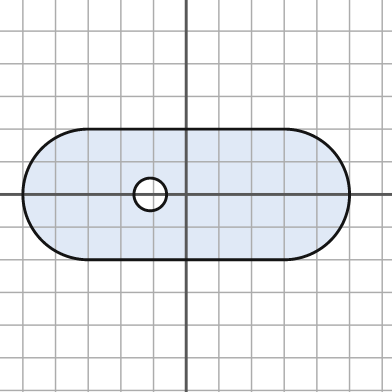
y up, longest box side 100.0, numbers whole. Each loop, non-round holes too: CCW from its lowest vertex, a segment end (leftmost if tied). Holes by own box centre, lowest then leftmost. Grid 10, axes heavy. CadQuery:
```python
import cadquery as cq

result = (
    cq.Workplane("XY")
    .moveTo(-30.0, -20.0)
    .lineTo(30.0, -20.0)
    .threePointArc((50.0, 0.0), (30.0, 20.0))
    .lineTo(-30.0, 20.0)
    .threePointArc((-50.0, 0.0), (-30.0, -20.0))
    .close()
    .moveTo(-11.0, 0.0)
    .circle(5.0)
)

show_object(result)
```